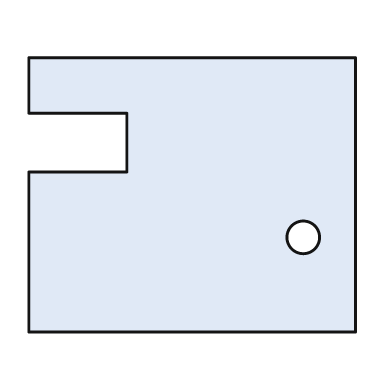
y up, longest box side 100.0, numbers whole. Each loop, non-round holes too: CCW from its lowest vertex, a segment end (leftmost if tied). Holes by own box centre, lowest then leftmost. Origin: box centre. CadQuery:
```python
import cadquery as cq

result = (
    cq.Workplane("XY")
    .moveTo(-50.0, -42.0)
    .lineTo(50.0, -42.0)
    .lineTo(50.0, 42.0)
    .lineTo(-50.0, 42.0)
    .lineTo(-50.0, 25.0)
    .lineTo(-20.0, 25.0)
    .lineTo(-20.0, 7.0)
    .lineTo(-50.0, 7.0)
    .close()
    .moveTo(34.0, -13.0)
    .circle(5.0)
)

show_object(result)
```